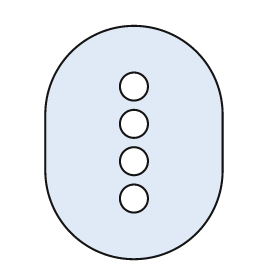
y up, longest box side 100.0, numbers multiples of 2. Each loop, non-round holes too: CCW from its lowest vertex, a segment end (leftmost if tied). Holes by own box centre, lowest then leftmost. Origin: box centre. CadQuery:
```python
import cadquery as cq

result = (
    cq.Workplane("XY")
    .moveTo(-38.0, -12.0)
    .threePointArc((0.0, -50.0), (38.0, -12.0))
    .lineTo(38.0, 12.0)
    .threePointArc((0.0, 50.0), (-38.0, 12.0))
    .close()
    .moveTo(0.0, -24.0)
    .circle(6.0)
    .moveTo(0.0, -8.0)
    .circle(6.0)
    .moveTo(0.0, 8.0)
    .circle(6.0)
    .moveTo(0.0, 24.0)
    .circle(6.0)
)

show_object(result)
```